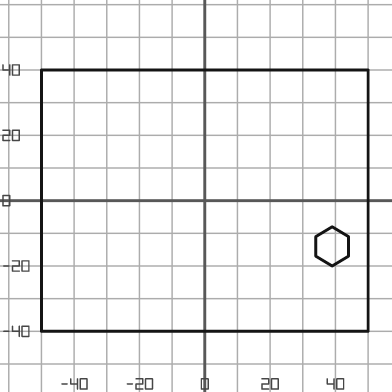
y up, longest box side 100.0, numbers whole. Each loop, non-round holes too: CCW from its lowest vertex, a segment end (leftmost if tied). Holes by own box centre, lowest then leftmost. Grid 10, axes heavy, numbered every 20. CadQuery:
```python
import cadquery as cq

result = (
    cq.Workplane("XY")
    .moveTo(-50.0, -40.0)
    .lineTo(50.0, -40.0)
    .lineTo(50.0, 40.0)
    .lineTo(-50.0, 40.0)
    .close()
    .moveTo(39.0, -20.0)
    .lineTo(44.0, -17.0)
    .lineTo(44.0, -11.0)
    .lineTo(39.0, -8.0)
    .lineTo(34.0, -11.0)
    .lineTo(34.0, -17.0)
    .close()
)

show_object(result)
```